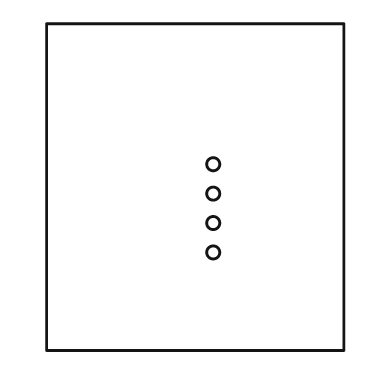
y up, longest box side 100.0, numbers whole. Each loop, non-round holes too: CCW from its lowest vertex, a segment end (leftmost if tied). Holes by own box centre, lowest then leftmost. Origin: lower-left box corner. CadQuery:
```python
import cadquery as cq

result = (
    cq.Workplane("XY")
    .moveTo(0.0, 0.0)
    .lineTo(91.0, 0.0)
    .lineTo(91.0, 100.0)
    .lineTo(0.0, 100.0)
    .close()
    .moveTo(51.0, 30.0)
    .circle(2.0)
    .moveTo(51.0, 39.0)
    .circle(2.0)
    .moveTo(51.0, 48.0)
    .circle(2.0)
    .moveTo(51.0, 57.0)
    .circle(2.0)
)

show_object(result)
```